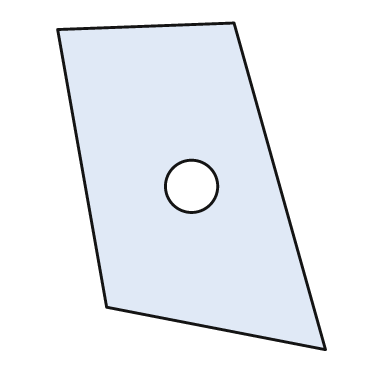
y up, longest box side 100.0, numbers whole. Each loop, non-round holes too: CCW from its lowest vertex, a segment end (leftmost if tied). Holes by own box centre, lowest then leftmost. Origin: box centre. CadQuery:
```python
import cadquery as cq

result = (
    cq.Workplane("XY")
    .moveTo(41.0, -50.0)
    .lineTo(13.0, 50.0)
    .lineTo(-41.0, 48.0)
    .lineTo(-26.0, -37.0)
    .close()
    .moveTo(0.0, 0.0)
    .circle(8.0)
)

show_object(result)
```